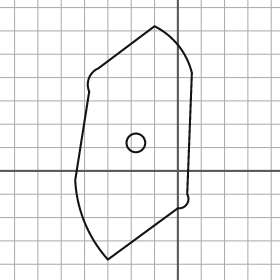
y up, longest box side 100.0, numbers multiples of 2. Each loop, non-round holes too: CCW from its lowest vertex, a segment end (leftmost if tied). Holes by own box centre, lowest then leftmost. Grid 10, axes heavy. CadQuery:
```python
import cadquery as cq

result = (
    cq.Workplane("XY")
    .moveTo(-30.0, -38.0)
    .lineTo(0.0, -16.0)
    .threePointArc((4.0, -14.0), (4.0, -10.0))
    .lineTo(6.0, 42.0)
    .threePointArc((0.0, 54.0), (-10.0, 62.0))
    .lineTo(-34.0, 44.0)
    .threePointArc((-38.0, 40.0), (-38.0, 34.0))
    .lineTo(-44.0, -4.0)
    .threePointArc((-40.0, -22.0), (-30.0, -38.0))
    .close()
    .moveTo(-18.0, 12.0)
    .circle(4.0)
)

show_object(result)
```